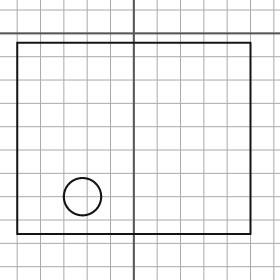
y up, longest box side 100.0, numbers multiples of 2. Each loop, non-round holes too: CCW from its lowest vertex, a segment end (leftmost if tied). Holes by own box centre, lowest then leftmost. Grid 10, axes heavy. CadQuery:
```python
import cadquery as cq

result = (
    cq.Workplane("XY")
    .moveTo(-50.0, -86.0)
    .lineTo(50.0, -86.0)
    .lineTo(50.0, -4.0)
    .lineTo(-50.0, -4.0)
    .close()
    .moveTo(-22.0, -70.0)
    .circle(8.0)
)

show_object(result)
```